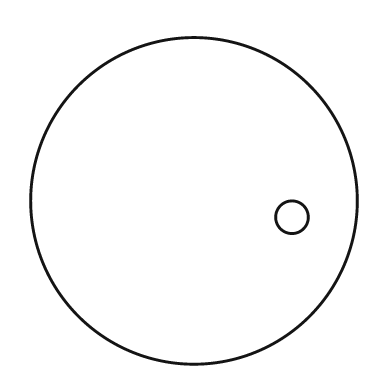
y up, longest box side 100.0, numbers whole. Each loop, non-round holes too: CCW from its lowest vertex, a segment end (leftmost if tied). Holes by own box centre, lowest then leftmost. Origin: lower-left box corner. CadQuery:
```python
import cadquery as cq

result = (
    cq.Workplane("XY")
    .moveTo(50.0, 50.0)
    .circle(50.0)
    .moveTo(80.0, 45.0)
    .circle(5.0)
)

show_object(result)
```